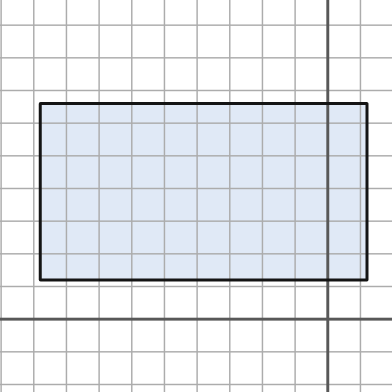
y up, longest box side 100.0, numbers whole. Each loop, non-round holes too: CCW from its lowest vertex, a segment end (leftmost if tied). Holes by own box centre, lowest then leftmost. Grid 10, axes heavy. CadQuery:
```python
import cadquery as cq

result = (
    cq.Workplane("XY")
    .moveTo(-88.0, 12.0)
    .lineTo(12.0, 12.0)
    .lineTo(12.0, 66.0)
    .lineTo(-88.0, 66.0)
    .close()
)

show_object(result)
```